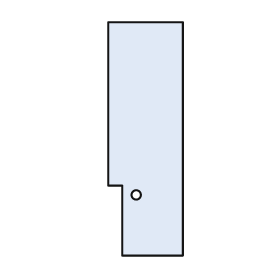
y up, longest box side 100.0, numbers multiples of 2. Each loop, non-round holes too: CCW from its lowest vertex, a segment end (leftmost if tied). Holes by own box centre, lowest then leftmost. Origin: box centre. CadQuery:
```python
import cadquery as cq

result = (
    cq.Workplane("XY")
    .moveTo(-10.0, -50.0)
    .lineTo(16.0, -50.0)
    .lineTo(16.0, 50.0)
    .lineTo(-16.0, 50.0)
    .lineTo(-16.0, -20.0)
    .lineTo(-10.0, -20.0)
    .close()
    .moveTo(-4.0, -24.0)
    .circle(2.0)
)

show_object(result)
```